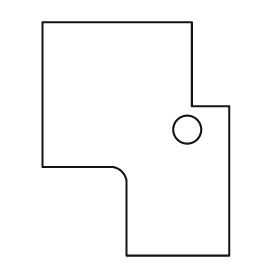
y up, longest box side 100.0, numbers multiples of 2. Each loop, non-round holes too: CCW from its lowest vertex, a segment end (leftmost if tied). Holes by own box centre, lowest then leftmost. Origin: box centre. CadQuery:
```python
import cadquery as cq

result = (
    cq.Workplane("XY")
    .moveTo(-4.0, -50.0)
    .lineTo(40.0, -50.0)
    .lineTo(40.0, 14.0)
    .lineTo(24.0, 14.0)
    .lineTo(24.0, 50.0)
    .lineTo(-40.0, 50.0)
    .lineTo(-40.0, -12.0)
    .lineTo(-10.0, -12.0)
    .threePointArc((-6.0, -14.0), (-4.0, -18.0))
    .close()
    .moveTo(22.0, 4.0)
    .circle(6.0)
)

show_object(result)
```